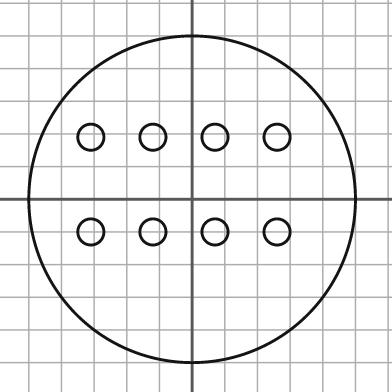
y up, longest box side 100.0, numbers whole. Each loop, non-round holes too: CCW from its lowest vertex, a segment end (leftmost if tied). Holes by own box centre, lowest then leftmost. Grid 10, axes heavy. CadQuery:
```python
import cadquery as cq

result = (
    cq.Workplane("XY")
    .moveTo(0.0, 0.0)
    .circle(50.0)
    .moveTo(-31.0, -10.0)
    .circle(4.0)
    .moveTo(-12.0, -10.0)
    .circle(4.0)
    .moveTo(7.0, -10.0)
    .circle(4.0)
    .moveTo(26.0, -10.0)
    .circle(4.0)
    .moveTo(-31.0, 19.0)
    .circle(4.0)
    .moveTo(-12.0, 19.0)
    .circle(4.0)
    .moveTo(7.0, 19.0)
    .circle(4.0)
    .moveTo(26.0, 19.0)
    .circle(4.0)
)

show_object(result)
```